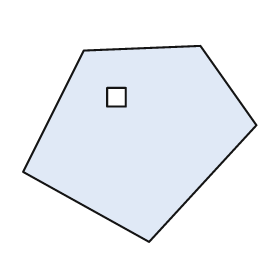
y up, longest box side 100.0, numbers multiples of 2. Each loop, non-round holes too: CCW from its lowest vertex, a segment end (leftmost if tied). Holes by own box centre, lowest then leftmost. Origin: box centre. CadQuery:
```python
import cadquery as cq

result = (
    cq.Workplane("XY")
    .moveTo(4.0, -42.0)
    .lineTo(50.0, 8.0)
    .lineTo(26.0, 42.0)
    .lineTo(-24.0, 40.0)
    .lineTo(-50.0, -12.0)
    .close()
    .moveTo(-14.0, 16.0)
    .lineTo(-6.0, 16.0)
    .lineTo(-6.0, 24.0)
    .lineTo(-14.0, 24.0)
    .close()
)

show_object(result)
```